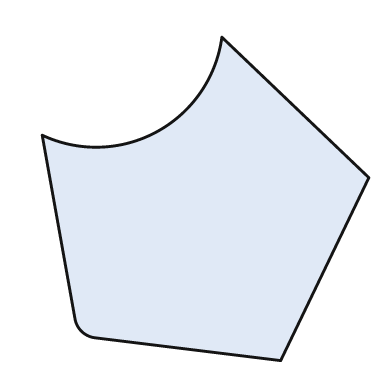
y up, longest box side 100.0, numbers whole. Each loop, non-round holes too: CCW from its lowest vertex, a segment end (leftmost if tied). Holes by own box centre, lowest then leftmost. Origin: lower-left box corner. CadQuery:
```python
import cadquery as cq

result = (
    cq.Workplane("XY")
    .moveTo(73.0, 0.0)
    .lineTo(100.0, 56.0)
    .lineTo(55.0, 99.0)
    .threePointArc((35.0, 70.0), (0.0, 69.0))
    .lineTo(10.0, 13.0)
    .threePointArc((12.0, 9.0), (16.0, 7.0))
    .close()
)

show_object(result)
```